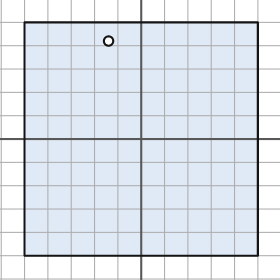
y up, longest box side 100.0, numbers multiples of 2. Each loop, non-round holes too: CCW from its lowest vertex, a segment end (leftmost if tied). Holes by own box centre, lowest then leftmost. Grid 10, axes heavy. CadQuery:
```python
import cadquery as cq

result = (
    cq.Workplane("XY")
    .moveTo(-50.0, -50.0)
    .lineTo(50.0, -50.0)
    .lineTo(50.0, 50.0)
    .lineTo(-50.0, 50.0)
    .close()
    .moveTo(-14.0, 42.0)
    .circle(2.0)
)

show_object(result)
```